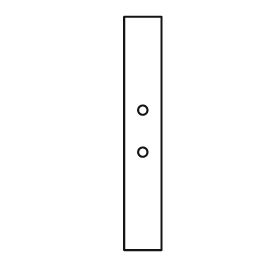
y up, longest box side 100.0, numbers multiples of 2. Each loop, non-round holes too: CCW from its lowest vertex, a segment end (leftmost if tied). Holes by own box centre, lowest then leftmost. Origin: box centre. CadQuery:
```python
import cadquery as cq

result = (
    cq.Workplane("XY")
    .moveTo(-8.0, -50.0)
    .lineTo(8.0, -50.0)
    .lineTo(8.0, 50.0)
    .lineTo(-8.0, 50.0)
    .close()
    .moveTo(0.0, -8.0)
    .circle(2.0)
    .moveTo(0.0, 10.0)
    .circle(2.0)
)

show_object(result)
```